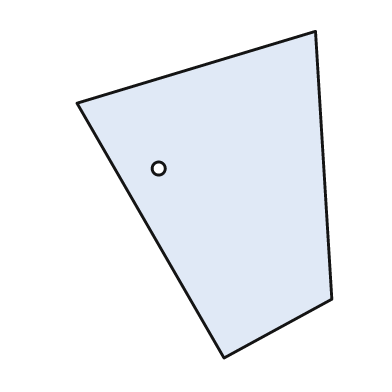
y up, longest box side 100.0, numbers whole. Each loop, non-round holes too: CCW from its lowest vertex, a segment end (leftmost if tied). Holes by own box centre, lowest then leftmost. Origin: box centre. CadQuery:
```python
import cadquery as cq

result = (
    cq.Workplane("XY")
    .moveTo(6.0, -50.0)
    .lineTo(39.0, -32.0)
    .lineTo(34.0, 50.0)
    .lineTo(-39.0, 28.0)
    .close()
    .moveTo(-14.0, 8.0)
    .circle(2.0)
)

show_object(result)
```